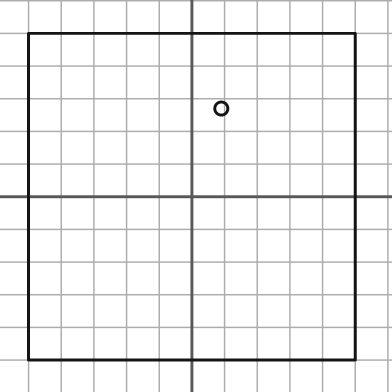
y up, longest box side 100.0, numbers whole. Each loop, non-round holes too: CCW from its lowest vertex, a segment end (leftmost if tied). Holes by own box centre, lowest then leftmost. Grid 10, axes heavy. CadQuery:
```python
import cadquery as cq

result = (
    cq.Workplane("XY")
    .moveTo(-50.0, -50.0)
    .lineTo(50.0, -50.0)
    .lineTo(50.0, 50.0)
    .lineTo(-50.0, 50.0)
    .close()
    .moveTo(9.0, 27.0)
    .circle(2.0)
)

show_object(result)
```